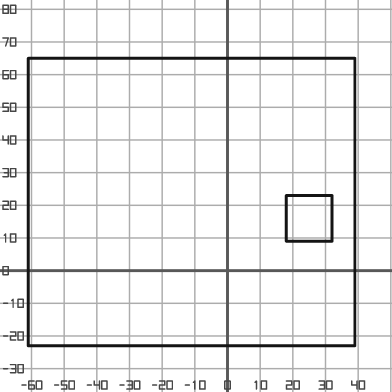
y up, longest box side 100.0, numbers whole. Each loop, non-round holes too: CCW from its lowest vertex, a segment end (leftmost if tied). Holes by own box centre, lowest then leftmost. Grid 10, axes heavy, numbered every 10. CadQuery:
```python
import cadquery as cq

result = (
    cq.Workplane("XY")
    .moveTo(-61.0, -23.0)
    .lineTo(39.0, -23.0)
    .lineTo(39.0, 65.0)
    .lineTo(-61.0, 65.0)
    .close()
    .moveTo(18.0, 9.0)
    .lineTo(32.0, 9.0)
    .lineTo(32.0, 23.0)
    .lineTo(18.0, 23.0)
    .close()
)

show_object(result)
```